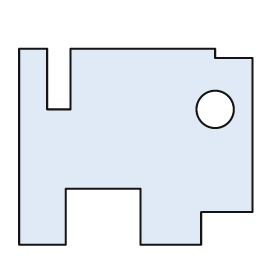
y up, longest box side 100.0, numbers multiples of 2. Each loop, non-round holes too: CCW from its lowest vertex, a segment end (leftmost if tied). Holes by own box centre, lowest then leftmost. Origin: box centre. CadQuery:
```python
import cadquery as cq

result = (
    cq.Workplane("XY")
    .moveTo(-50.0, -42.0)
    .lineTo(-30.0, -42.0)
    .lineTo(-30.0, -18.0)
    .lineTo(2.0, -18.0)
    .lineTo(2.0, -42.0)
    .lineTo(28.0, -42.0)
    .lineTo(28.0, -28.0)
    .lineTo(50.0, -28.0)
    .lineTo(50.0, 38.0)
    .lineTo(34.0, 38.0)
    .lineTo(34.0, 42.0)
    .lineTo(-28.0, 42.0)
    .lineTo(-28.0, 16.0)
    .lineTo(-38.0, 16.0)
    .lineTo(-38.0, 42.0)
    .lineTo(-50.0, 42.0)
    .close()
    .moveTo(34.0, 16.0)
    .circle(8.0)
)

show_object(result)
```